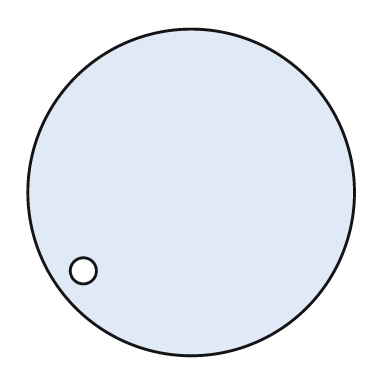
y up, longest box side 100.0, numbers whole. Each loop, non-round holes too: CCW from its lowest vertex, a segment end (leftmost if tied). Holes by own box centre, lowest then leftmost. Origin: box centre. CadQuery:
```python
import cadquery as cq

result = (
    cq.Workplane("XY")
    .moveTo(0.0, 0.0)
    .circle(50.0)
    .moveTo(-33.0, -24.0)
    .circle(4.0)
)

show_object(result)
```